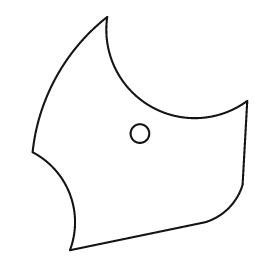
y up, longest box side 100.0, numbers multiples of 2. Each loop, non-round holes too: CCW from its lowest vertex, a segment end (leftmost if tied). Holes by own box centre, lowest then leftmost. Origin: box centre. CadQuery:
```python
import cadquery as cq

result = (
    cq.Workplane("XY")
    .moveTo(-30.0, -50.0)
    .lineTo(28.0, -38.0)
    .threePointArc((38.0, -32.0), (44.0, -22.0))
    .lineTo(46.0, 14.0)
    .threePointArc((4.0, 12.0), (-14.0, 50.0))
    .threePointArc((-36.0, 24.0), (-46.0, -8.0))
    .threePointArc((-30.0, -26.0), (-30.0, -50.0))
    .close()
    .moveTo(0.0, 0.0)
    .circle(4.0)
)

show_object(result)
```